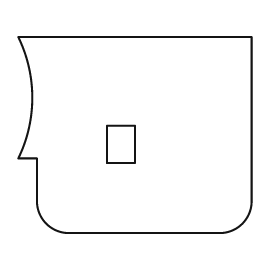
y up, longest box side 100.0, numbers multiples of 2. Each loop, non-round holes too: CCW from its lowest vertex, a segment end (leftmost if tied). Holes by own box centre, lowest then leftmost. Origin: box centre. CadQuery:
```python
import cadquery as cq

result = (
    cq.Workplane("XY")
    .moveTo(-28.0, -42.0)
    .lineTo(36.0, -42.0)
    .threePointArc((46.0, -38.0), (50.0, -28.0))
    .lineTo(50.0, 42.0)
    .lineTo(-50.0, 42.0)
    .threePointArc((-44.0, 16.0), (-50.0, -10.0))
    .lineTo(-42.0, -10.0)
    .lineTo(-42.0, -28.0)
    .threePointArc((-38.0, -38.0), (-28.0, -42.0))
    .close()
    .moveTo(-12.0, -12.0)
    .lineTo(0.0, -12.0)
    .lineTo(0.0, 4.0)
    .lineTo(-12.0, 4.0)
    .close()
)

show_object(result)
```